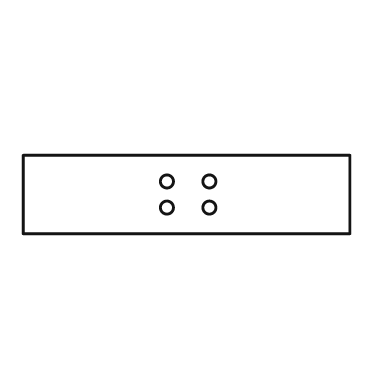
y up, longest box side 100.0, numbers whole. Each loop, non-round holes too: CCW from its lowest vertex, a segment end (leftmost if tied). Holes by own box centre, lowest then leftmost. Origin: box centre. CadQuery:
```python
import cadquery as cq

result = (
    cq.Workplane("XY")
    .moveTo(-50.0, -12.0)
    .lineTo(50.0, -12.0)
    .lineTo(50.0, 12.0)
    .lineTo(-50.0, 12.0)
    .close()
    .moveTo(-6.0, -4.0)
    .circle(2.0)
    .moveTo(7.0, -4.0)
    .circle(2.0)
    .moveTo(-6.0, 4.0)
    .circle(2.0)
    .moveTo(7.0, 4.0)
    .circle(2.0)
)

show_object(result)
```